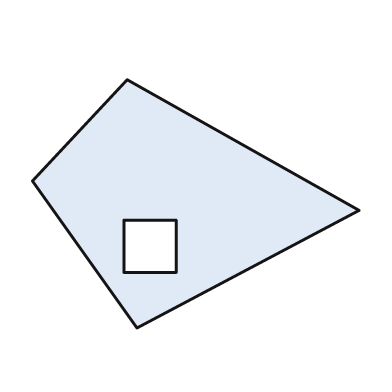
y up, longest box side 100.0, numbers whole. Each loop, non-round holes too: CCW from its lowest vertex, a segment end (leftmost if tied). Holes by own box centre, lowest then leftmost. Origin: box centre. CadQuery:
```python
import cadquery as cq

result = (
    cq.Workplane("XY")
    .moveTo(-18.0, -38.0)
    .lineTo(50.0, -2.0)
    .lineTo(-21.0, 38.0)
    .lineTo(-50.0, 7.0)
    .close()
    .moveTo(-22.0, -21.0)
    .lineTo(-6.0, -21.0)
    .lineTo(-6.0, -5.0)
    .lineTo(-22.0, -5.0)
    .close()
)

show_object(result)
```